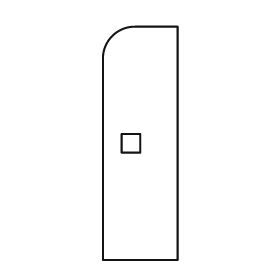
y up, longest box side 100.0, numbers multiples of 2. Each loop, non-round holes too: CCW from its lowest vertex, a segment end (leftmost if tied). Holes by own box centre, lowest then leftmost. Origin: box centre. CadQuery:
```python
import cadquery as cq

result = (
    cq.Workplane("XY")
    .moveTo(-16.0, -50.0)
    .lineTo(16.0, -50.0)
    .lineTo(16.0, 50.0)
    .lineTo(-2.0, 50.0)
    .threePointArc((-12.0, 46.0), (-16.0, 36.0))
    .close()
    .moveTo(-8.0, -4.0)
    .lineTo(0.0, -4.0)
    .lineTo(0.0, 4.0)
    .lineTo(-8.0, 4.0)
    .close()
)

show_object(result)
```